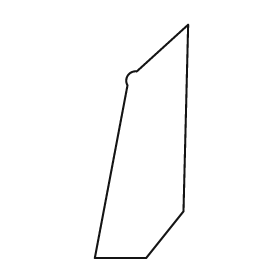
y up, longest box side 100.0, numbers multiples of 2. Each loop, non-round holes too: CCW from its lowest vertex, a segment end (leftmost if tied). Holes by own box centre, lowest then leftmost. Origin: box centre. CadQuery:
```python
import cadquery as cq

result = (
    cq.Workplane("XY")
    .moveTo(-20.0, -50.0)
    .lineTo(2.0, -50.0)
    .lineTo(18.0, -30.0)
    .lineTo(20.0, 50.0)
    .lineTo(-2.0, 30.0)
    .threePointArc((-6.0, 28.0), (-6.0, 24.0))
    .close()
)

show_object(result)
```